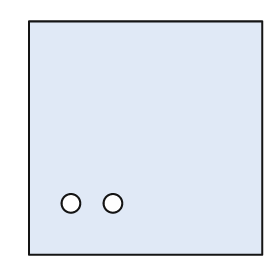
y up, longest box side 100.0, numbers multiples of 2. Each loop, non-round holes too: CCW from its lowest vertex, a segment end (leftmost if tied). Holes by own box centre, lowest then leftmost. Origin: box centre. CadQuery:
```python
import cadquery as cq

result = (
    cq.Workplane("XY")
    .moveTo(-50.0, -50.0)
    .lineTo(50.0, -50.0)
    .lineTo(50.0, 50.0)
    .lineTo(-50.0, 50.0)
    .close()
    .moveTo(-32.0, -28.0)
    .circle(4.0)
    .moveTo(-14.0, -28.0)
    .circle(4.0)
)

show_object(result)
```